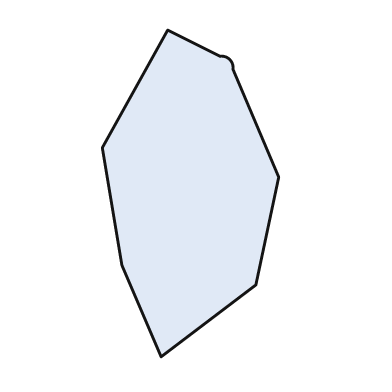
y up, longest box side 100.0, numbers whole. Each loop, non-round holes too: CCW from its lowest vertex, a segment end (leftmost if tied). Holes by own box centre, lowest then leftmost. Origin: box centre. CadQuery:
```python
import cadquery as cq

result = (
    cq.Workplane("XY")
    .moveTo(-9.0, -50.0)
    .lineTo(20.0, -28.0)
    .lineTo(27.0, 5.0)
    .lineTo(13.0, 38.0)
    .threePointArc((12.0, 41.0), (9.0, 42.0))
    .lineTo(-7.0, 50.0)
    .lineTo(-27.0, 14.0)
    .lineTo(-21.0, -22.0)
    .close()
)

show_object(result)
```